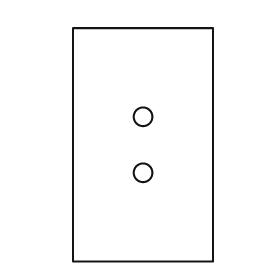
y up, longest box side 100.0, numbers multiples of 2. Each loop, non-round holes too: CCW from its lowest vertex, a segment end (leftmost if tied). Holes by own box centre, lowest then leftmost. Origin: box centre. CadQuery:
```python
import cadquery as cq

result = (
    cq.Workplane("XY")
    .moveTo(-30.0, -50.0)
    .lineTo(30.0, -50.0)
    .lineTo(30.0, 50.0)
    .lineTo(-30.0, 50.0)
    .close()
    .moveTo(0.0, -12.0)
    .circle(4.0)
    .moveTo(0.0, 12.0)
    .circle(4.0)
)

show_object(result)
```